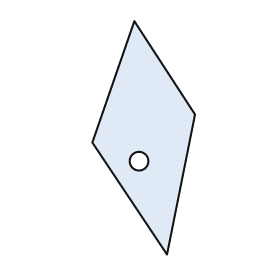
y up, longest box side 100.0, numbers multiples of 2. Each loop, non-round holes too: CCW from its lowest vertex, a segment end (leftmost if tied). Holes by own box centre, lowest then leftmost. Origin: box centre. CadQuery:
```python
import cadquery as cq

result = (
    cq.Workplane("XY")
    .moveTo(10.0, -50.0)
    .lineTo(22.0, 10.0)
    .lineTo(-4.0, 50.0)
    .lineTo(-22.0, -2.0)
    .close()
    .moveTo(-2.0, -10.0)
    .circle(4.0)
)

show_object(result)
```